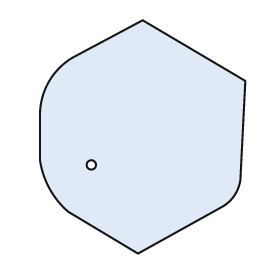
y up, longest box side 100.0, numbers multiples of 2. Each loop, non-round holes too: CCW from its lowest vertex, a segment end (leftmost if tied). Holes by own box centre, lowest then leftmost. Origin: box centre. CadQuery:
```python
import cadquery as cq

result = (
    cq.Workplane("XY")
    .moveTo(-2.0, -50.0)
    .lineTo(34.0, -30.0)
    .threePointArc((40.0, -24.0), (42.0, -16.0))
    .lineTo(44.0, 24.0)
    .lineTo(0.0, 50.0)
    .lineTo(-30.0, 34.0)
    .threePointArc((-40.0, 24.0), (-44.0, 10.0))
    .lineTo(-44.0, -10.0)
    .threePointArc((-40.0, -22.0), (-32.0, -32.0))
    .close()
    .moveTo(-22.0, -12.0)
    .circle(2.0)
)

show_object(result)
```